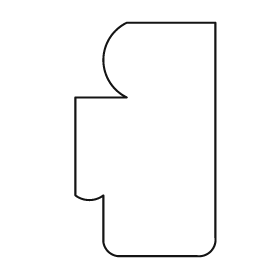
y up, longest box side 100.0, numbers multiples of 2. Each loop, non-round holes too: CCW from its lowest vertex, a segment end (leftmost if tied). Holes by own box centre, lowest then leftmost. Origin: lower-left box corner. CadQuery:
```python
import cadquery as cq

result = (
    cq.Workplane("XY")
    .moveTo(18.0, 0.0)
    .lineTo(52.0, 0.0)
    .threePointArc((58.0, 2.0), (60.0, 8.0))
    .lineTo(60.0, 100.0)
    .lineTo(22.0, 100.0)
    .threePointArc((12.0, 84.0), (22.0, 68.0))
    .lineTo(0.0, 68.0)
    .lineTo(0.0, 26.0)
    .threePointArc((6.0, 24.0), (12.0, 26.0))
    .lineTo(12.0, 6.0)
    .threePointArc((14.0, 2.0), (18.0, 0.0))
    .close()
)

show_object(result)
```